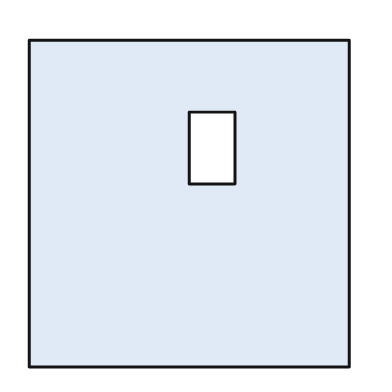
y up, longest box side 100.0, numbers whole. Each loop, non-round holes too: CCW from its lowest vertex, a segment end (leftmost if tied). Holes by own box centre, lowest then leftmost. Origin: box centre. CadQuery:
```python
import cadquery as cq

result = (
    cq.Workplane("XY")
    .moveTo(-49.0, -50.0)
    .lineTo(49.0, -50.0)
    .lineTo(49.0, 50.0)
    .lineTo(-49.0, 50.0)
    .close()
    .moveTo(0.0, 6.0)
    .lineTo(14.0, 6.0)
    .lineTo(14.0, 28.0)
    .lineTo(0.0, 28.0)
    .close()
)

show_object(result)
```